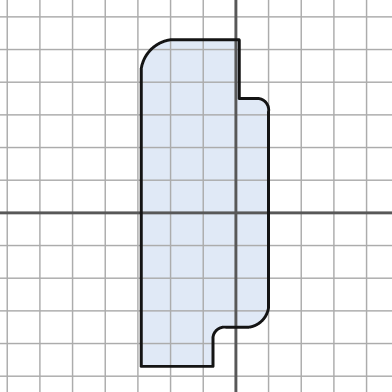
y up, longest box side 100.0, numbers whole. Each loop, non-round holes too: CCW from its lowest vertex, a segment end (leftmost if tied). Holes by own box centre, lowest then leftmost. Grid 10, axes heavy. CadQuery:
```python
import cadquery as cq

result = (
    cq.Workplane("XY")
    .moveTo(-29.0, -47.0)
    .lineTo(-7.0, -47.0)
    .lineTo(-7.0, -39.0)
    .threePointArc((-6.0, -36.0), (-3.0, -35.0))
    .lineTo(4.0, -35.0)
    .threePointArc((8.0, -33.0), (10.0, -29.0))
    .lineTo(10.0, 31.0)
    .threePointArc((9.0, 34.0), (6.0, 35.0))
    .lineTo(1.0, 35.0)
    .lineTo(1.0, 53.0)
    .lineTo(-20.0, 53.0)
    .threePointArc((-26.0, 50.0), (-29.0, 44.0))
    .close()
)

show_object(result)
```